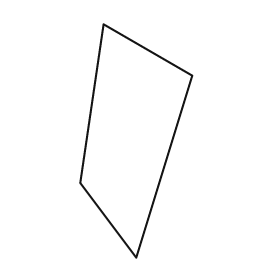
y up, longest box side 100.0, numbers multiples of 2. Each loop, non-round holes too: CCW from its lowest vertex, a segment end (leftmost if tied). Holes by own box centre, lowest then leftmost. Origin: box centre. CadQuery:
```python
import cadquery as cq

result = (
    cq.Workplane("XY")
    .moveTo(0.0, -50.0)
    .lineTo(24.0, 28.0)
    .lineTo(-14.0, 50.0)
    .lineTo(-24.0, -18.0)
    .close()
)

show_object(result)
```